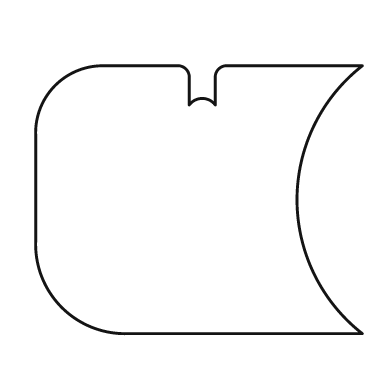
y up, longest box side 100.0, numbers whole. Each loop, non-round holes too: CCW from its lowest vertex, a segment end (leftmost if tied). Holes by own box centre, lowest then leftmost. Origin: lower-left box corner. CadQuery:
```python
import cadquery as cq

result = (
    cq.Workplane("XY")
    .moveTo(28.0, 0.0)
    .lineTo(100.0, 0.0)
    .threePointArc((80.0, 41.0), (100.0, 82.0))
    .lineTo(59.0, 82.0)
    .threePointArc((56.0, 81.0), (55.0, 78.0))
    .lineTo(55.0, 70.0)
    .threePointArc((51.0, 72.0), (47.0, 70.0))
    .lineTo(47.0, 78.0)
    .threePointArc((46.0, 81.0), (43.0, 82.0))
    .lineTo(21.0, 82.0)
    .threePointArc((6.0, 76.0), (0.0, 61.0))
    .lineTo(0.0, 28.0)
    .threePointArc((8.0, 8.0), (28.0, 0.0))
    .close()
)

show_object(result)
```